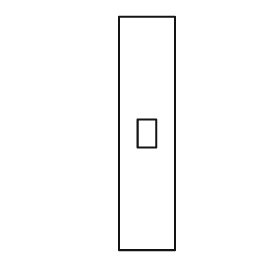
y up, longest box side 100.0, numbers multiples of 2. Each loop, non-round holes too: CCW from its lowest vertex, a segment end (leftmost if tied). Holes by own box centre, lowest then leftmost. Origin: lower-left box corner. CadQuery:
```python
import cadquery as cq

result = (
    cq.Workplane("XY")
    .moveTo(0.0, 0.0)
    .lineTo(24.0, 0.0)
    .lineTo(24.0, 100.0)
    .lineTo(0.0, 100.0)
    .close()
    .moveTo(8.0, 44.0)
    .lineTo(16.0, 44.0)
    .lineTo(16.0, 56.0)
    .lineTo(8.0, 56.0)
    .close()
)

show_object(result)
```